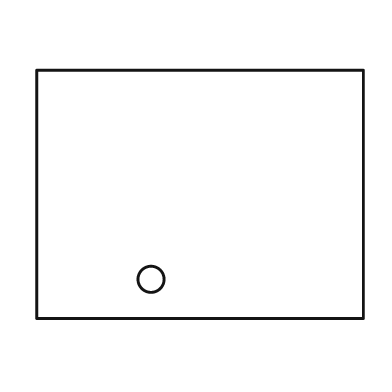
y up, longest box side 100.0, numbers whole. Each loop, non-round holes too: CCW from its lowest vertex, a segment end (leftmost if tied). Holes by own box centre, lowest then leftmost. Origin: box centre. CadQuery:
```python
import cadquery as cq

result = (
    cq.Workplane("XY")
    .moveTo(-50.0, -38.0)
    .lineTo(50.0, -38.0)
    .lineTo(50.0, 38.0)
    .lineTo(-50.0, 38.0)
    .close()
    .moveTo(-15.0, -26.0)
    .circle(4.0)
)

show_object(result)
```